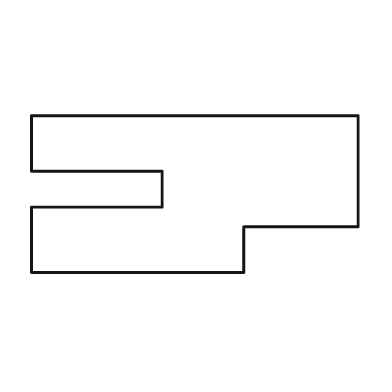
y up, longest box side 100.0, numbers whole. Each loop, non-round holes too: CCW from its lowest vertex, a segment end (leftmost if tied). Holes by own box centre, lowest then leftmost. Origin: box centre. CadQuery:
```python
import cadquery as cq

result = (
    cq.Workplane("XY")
    .moveTo(-50.0, -24.0)
    .lineTo(15.0, -24.0)
    .lineTo(15.0, -10.0)
    .lineTo(50.0, -10.0)
    .lineTo(50.0, 24.0)
    .lineTo(-50.0, 24.0)
    .lineTo(-50.0, 7.0)
    .lineTo(-10.0, 7.0)
    .lineTo(-10.0, -4.0)
    .lineTo(-50.0, -4.0)
    .close()
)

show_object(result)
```